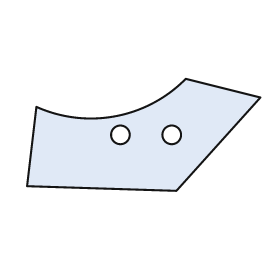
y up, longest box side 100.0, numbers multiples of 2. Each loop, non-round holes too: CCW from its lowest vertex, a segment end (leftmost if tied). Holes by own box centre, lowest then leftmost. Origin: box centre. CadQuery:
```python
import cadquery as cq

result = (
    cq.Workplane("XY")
    .moveTo(14.0, -24.0)
    .lineTo(50.0, 16.0)
    .lineTo(18.0, 24.0)
    .threePointArc((-12.0, 8.0), (-46.0, 12.0))
    .lineTo(-50.0, -22.0)
    .close()
    .moveTo(-10.0, 0.0)
    .circle(4.0)
    .moveTo(12.0, 0.0)
    .circle(4.0)
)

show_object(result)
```